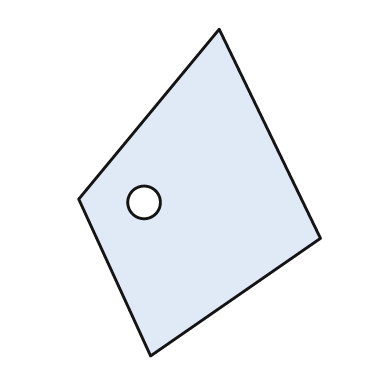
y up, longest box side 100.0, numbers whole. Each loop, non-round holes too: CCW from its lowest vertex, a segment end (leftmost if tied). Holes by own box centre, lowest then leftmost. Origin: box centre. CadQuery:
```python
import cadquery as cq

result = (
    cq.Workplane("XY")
    .moveTo(-15.0, -50.0)
    .lineTo(37.0, -14.0)
    .lineTo(6.0, 50.0)
    .lineTo(-37.0, -2.0)
    .close()
    .moveTo(-17.0, -3.0)
    .circle(5.0)
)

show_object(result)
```